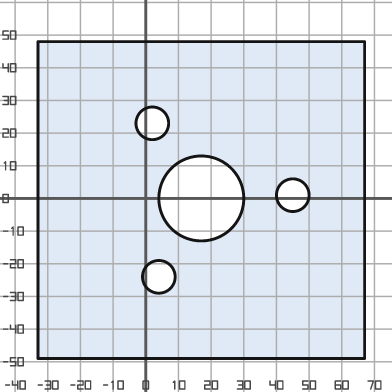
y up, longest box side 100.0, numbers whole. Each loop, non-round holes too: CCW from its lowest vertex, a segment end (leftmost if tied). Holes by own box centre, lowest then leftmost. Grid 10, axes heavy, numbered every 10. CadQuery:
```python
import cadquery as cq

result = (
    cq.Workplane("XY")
    .moveTo(-33.0, -49.0)
    .lineTo(67.0, -49.0)
    .lineTo(67.0, 48.0)
    .lineTo(-33.0, 48.0)
    .close()
    .moveTo(4.0, -24.0)
    .circle(5.0)
    .moveTo(17.0, 0.0)
    .circle(13.0)
    .moveTo(45.0, 1.0)
    .circle(5.0)
    .moveTo(2.0, 23.0)
    .circle(5.0)
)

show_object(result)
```